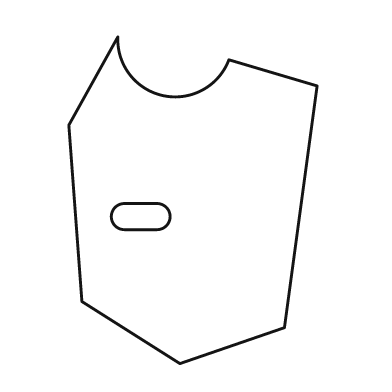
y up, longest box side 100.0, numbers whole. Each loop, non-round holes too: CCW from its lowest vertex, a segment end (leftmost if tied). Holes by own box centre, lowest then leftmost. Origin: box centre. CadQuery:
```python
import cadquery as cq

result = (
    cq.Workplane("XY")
    .moveTo(-4.0, -50.0)
    .lineTo(28.0, -39.0)
    .lineTo(38.0, 35.0)
    .lineTo(11.0, 43.0)
    .threePointArc((-9.0, 32.0), (-23.0, 50.0))
    .lineTo(-38.0, 23.0)
    .lineTo(-34.0, -31.0)
    .close()
    .moveTo(-21.0, -9.0)
    .lineTo(-11.0, -9.0)
    .threePointArc((-7.0, -5.0), (-11.0, -1.0))
    .lineTo(-21.0, -1.0)
    .threePointArc((-25.0, -5.0), (-21.0, -9.0))
    .close()
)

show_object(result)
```